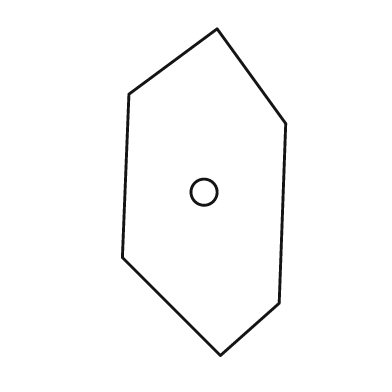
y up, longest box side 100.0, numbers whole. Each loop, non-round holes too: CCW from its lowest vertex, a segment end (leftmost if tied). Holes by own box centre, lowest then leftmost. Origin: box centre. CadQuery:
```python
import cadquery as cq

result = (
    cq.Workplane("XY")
    .moveTo(5.0, -50.0)
    .lineTo(23.0, -34.0)
    .lineTo(25.0, 21.0)
    .lineTo(4.0, 50.0)
    .lineTo(-23.0, 30.0)
    .lineTo(-25.0, -20.0)
    .close()
    .moveTo(0.0, 0.0)
    .circle(4.0)
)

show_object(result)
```